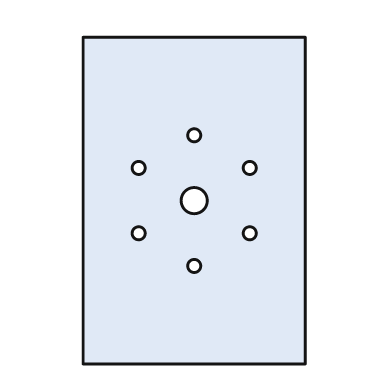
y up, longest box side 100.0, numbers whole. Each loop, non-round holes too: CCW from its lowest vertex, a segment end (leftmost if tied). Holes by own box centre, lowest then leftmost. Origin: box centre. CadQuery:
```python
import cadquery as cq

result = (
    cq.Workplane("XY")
    .moveTo(-34.0, -50.0)
    .lineTo(34.0, -50.0)
    .lineTo(34.0, 50.0)
    .lineTo(-34.0, 50.0)
    .close()
    .moveTo(0.0, -20.0)
    .circle(2.0)
    .moveTo(-17.0, -10.0)
    .circle(2.0)
    .moveTo(17.0, -10.0)
    .circle(2.0)
    .moveTo(0.0, 0.0)
    .circle(4.0)
    .moveTo(-17.0, 10.0)
    .circle(2.0)
    .moveTo(17.0, 10.0)
    .circle(2.0)
    .moveTo(0.0, 20.0)
    .circle(2.0)
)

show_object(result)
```